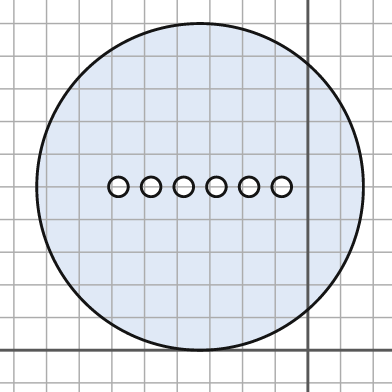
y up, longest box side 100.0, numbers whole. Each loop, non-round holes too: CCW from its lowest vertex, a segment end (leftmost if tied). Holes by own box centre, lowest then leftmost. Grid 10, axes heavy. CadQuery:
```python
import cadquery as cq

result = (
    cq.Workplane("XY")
    .moveTo(-33.0, 50.0)
    .circle(50.0)
    .moveTo(-58.0, 50.0)
    .circle(3.0)
    .moveTo(-48.0, 50.0)
    .circle(3.0)
    .moveTo(-38.0, 50.0)
    .circle(3.0)
    .moveTo(-28.0, 50.0)
    .circle(3.0)
    .moveTo(-18.0, 50.0)
    .circle(3.0)
    .moveTo(-8.0, 50.0)
    .circle(3.0)
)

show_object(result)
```